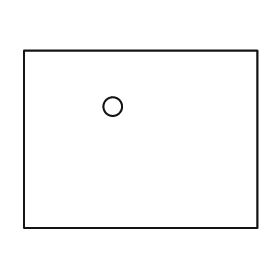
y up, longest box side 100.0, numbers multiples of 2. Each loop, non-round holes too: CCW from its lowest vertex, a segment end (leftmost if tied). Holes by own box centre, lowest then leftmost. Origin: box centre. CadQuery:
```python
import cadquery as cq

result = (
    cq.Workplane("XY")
    .moveTo(-50.0, -38.0)
    .lineTo(50.0, -38.0)
    .lineTo(50.0, 38.0)
    .lineTo(-50.0, 38.0)
    .close()
    .moveTo(-12.0, 14.0)
    .circle(4.0)
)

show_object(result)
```